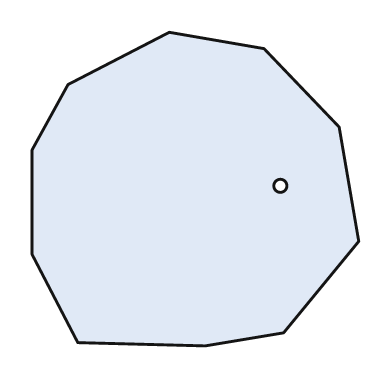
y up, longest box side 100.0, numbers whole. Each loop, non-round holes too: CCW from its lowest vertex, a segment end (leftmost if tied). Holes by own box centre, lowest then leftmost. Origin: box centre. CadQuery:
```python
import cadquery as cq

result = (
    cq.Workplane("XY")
    .moveTo(3.0, -48.0)
    .lineTo(27.0, -44.0)
    .lineTo(50.0, -16.0)
    .lineTo(44.0, 19.0)
    .lineTo(21.0, 43.0)
    .lineTo(-8.0, 48.0)
    .lineTo(-39.0, 32.0)
    .lineTo(-50.0, 12.0)
    .lineTo(-50.0, -20.0)
    .lineTo(-36.0, -47.0)
    .close()
    .moveTo(26.0, 1.0)
    .circle(2.0)
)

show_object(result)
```